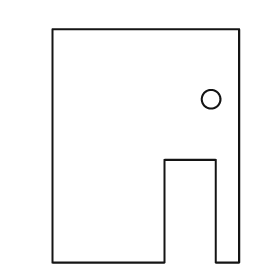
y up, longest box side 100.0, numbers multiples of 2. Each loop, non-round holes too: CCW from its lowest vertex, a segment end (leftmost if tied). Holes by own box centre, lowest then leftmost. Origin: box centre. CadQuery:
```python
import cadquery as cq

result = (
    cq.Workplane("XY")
    .moveTo(-40.0, -50.0)
    .lineTo(8.0, -50.0)
    .lineTo(8.0, -6.0)
    .lineTo(30.0, -6.0)
    .lineTo(30.0, -50.0)
    .lineTo(40.0, -50.0)
    .lineTo(40.0, 50.0)
    .lineTo(-40.0, 50.0)
    .close()
    .moveTo(28.0, 20.0)
    .circle(4.0)
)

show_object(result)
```